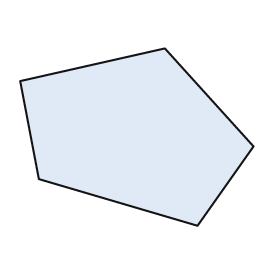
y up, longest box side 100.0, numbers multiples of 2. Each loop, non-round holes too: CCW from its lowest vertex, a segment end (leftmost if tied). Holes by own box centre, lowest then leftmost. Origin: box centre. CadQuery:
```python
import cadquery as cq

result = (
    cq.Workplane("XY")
    .moveTo(26.0, -38.0)
    .lineTo(50.0, -4.0)
    .lineTo(12.0, 38.0)
    .lineTo(-50.0, 24.0)
    .lineTo(-42.0, -18.0)
    .close()
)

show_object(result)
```